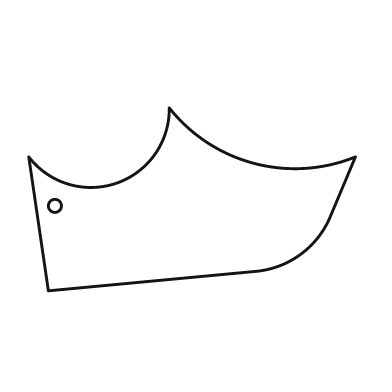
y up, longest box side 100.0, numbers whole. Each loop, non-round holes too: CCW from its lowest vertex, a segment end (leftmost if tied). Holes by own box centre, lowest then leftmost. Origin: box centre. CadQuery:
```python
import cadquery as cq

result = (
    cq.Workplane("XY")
    .moveTo(-44.0, -28.0)
    .lineTo(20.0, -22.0)
    .threePointArc((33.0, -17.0), (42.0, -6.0))
    .lineTo(50.0, 13.0)
    .threePointArc((19.0, 11.0), (-7.0, 28.0))
    .threePointArc((-23.0, 5.0), (-50.0, 13.0))
    .close()
    .moveTo(-42.0, -2.0)
    .circle(2.0)
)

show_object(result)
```